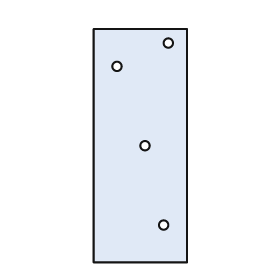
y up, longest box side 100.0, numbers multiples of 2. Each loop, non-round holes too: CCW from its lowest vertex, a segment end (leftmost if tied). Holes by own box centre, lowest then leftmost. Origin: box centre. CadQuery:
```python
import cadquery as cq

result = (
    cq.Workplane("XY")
    .moveTo(-20.0, -50.0)
    .lineTo(20.0, -50.0)
    .lineTo(20.0, 50.0)
    .lineTo(-20.0, 50.0)
    .close()
    .moveTo(10.0, -34.0)
    .circle(2.0)
    .moveTo(2.0, 0.0)
    .circle(2.0)
    .moveTo(-10.0, 34.0)
    .circle(2.0)
    .moveTo(12.0, 44.0)
    .circle(2.0)
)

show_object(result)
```